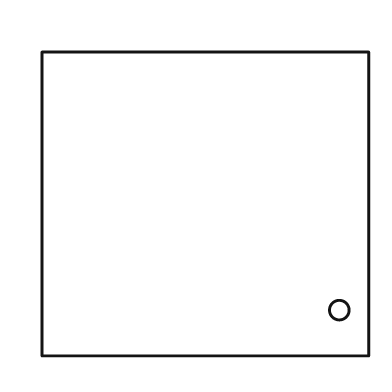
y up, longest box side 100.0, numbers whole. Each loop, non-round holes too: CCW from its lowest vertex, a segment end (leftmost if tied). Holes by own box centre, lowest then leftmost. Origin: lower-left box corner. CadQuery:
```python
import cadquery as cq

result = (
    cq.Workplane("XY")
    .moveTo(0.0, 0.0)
    .lineTo(100.0, 0.0)
    .lineTo(100.0, 93.0)
    .lineTo(0.0, 93.0)
    .close()
    .moveTo(91.0, 14.0)
    .circle(3.0)
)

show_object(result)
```